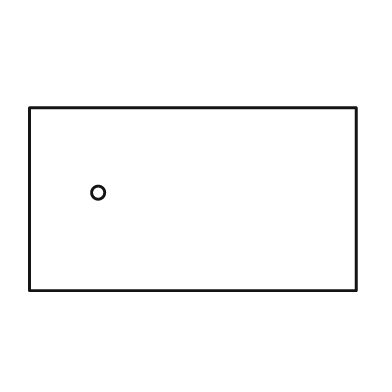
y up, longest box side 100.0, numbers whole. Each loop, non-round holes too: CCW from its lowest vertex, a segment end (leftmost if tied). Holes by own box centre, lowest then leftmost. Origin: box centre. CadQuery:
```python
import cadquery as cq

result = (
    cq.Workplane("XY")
    .moveTo(-50.0, -28.0)
    .lineTo(50.0, -28.0)
    .lineTo(50.0, 28.0)
    .lineTo(-50.0, 28.0)
    .close()
    .moveTo(-29.0, 2.0)
    .circle(2.0)
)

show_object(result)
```